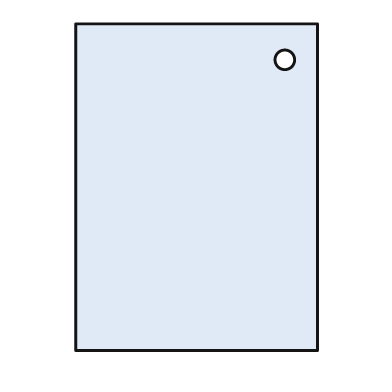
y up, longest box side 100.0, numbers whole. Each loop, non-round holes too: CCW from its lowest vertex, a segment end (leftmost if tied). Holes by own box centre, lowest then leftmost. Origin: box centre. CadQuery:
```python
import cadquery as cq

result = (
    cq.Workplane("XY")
    .moveTo(-37.0, -50.0)
    .lineTo(37.0, -50.0)
    .lineTo(37.0, 50.0)
    .lineTo(-37.0, 50.0)
    .close()
    .moveTo(27.0, 39.0)
    .circle(3.0)
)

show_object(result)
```